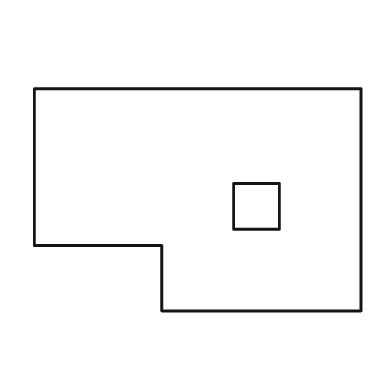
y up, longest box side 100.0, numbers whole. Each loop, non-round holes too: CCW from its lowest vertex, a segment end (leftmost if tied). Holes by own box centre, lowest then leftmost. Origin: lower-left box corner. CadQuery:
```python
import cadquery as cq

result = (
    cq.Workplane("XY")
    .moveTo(39.0, 0.0)
    .lineTo(100.0, 0.0)
    .lineTo(100.0, 68.0)
    .lineTo(0.0, 68.0)
    .lineTo(0.0, 20.0)
    .lineTo(39.0, 20.0)
    .close()
    .moveTo(61.0, 25.0)
    .lineTo(75.0, 25.0)
    .lineTo(75.0, 39.0)
    .lineTo(61.0, 39.0)
    .close()
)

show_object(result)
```